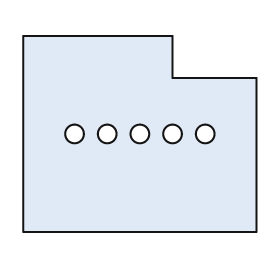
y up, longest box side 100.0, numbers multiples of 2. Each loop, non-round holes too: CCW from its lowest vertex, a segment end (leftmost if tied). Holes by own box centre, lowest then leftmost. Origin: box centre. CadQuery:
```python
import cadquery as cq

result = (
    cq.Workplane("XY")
    .moveTo(-50.0, -42.0)
    .lineTo(50.0, -42.0)
    .lineTo(50.0, 24.0)
    .lineTo(14.0, 24.0)
    .lineTo(14.0, 42.0)
    .lineTo(-50.0, 42.0)
    .close()
    .moveTo(-28.0, 0.0)
    .circle(4.0)
    .moveTo(-14.0, 0.0)
    .circle(4.0)
    .moveTo(0.0, 0.0)
    .circle(4.0)
    .moveTo(14.0, 0.0)
    .circle(4.0)
    .moveTo(28.0, 0.0)
    .circle(4.0)
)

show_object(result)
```